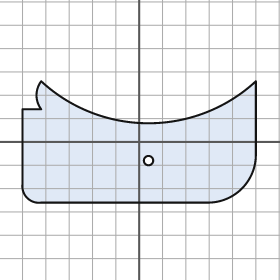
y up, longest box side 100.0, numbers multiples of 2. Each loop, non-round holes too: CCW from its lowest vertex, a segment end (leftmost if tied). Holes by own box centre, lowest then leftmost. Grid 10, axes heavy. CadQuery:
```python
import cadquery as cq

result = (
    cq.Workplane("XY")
    .moveTo(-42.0, -26.0)
    .lineTo(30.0, -26.0)
    .threePointArc((44.0, -20.0), (50.0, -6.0))
    .lineTo(50.0, 26.0)
    .threePointArc((4.0, 8.0), (-42.0, 26.0))
    .threePointArc((-44.0, 20.0), (-42.0, 14.0))
    .lineTo(-50.0, 14.0)
    .lineTo(-50.0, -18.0)
    .threePointArc((-48.0, -24.0), (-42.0, -26.0))
    .close()
    .moveTo(4.0, -8.0)
    .circle(2.0)
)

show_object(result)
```